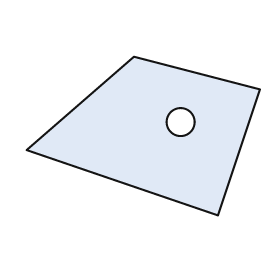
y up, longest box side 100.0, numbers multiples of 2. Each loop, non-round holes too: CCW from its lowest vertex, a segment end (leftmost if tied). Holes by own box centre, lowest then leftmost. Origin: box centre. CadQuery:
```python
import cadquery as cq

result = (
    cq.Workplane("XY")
    .moveTo(32.0, -34.0)
    .lineTo(50.0, 20.0)
    .lineTo(-4.0, 34.0)
    .lineTo(-50.0, -6.0)
    .close()
    .moveTo(16.0, 6.0)
    .circle(6.0)
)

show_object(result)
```